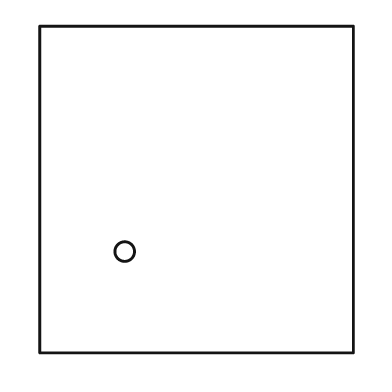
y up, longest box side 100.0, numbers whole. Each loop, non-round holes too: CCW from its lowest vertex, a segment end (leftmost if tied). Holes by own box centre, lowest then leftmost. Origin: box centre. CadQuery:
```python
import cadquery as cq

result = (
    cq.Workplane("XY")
    .moveTo(-48.0, -50.0)
    .lineTo(48.0, -50.0)
    .lineTo(48.0, 50.0)
    .lineTo(-48.0, 50.0)
    .close()
    .moveTo(-22.0, -19.0)
    .circle(3.0)
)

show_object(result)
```